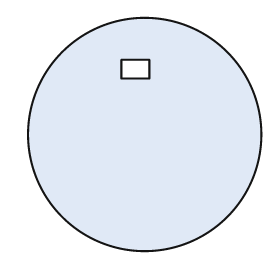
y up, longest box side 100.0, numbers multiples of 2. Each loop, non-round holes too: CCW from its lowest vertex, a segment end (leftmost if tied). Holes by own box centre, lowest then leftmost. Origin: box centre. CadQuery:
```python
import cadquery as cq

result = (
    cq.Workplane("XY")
    .moveTo(0.0, 0.0)
    .circle(50.0)
    .moveTo(-10.0, 24.0)
    .lineTo(2.0, 24.0)
    .lineTo(2.0, 32.0)
    .lineTo(-10.0, 32.0)
    .close()
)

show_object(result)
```